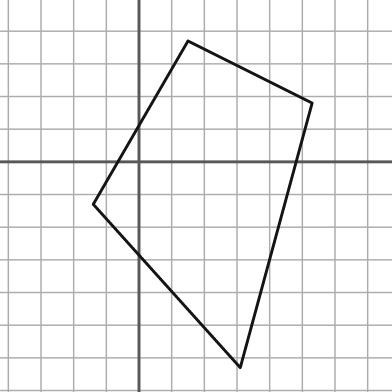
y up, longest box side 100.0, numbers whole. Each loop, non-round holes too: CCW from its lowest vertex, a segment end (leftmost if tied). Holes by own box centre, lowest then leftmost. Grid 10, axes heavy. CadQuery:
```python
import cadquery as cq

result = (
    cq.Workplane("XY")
    .moveTo(31.0, -63.0)
    .lineTo(53.0, 18.0)
    .lineTo(15.0, 37.0)
    .lineTo(-14.0, -13.0)
    .close()
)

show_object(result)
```